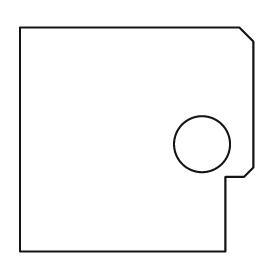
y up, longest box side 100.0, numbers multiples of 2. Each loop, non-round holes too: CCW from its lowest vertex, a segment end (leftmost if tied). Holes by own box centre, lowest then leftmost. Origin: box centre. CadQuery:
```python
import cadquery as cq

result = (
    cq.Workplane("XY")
    .moveTo(-50.0, -48.0)
    .lineTo(38.0, -48.0)
    .lineTo(38.0, -16.0)
    .lineTo(46.0, -16.0)
    .lineTo(50.0, -12.0)
    .lineTo(50.0, 42.0)
    .lineTo(44.0, 48.0)
    .lineTo(-50.0, 48.0)
    .close()
    .moveTo(28.0, -2.0)
    .circle(12.0)
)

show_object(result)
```